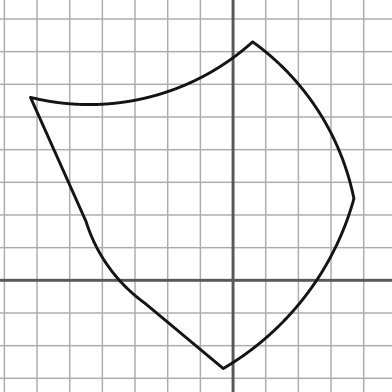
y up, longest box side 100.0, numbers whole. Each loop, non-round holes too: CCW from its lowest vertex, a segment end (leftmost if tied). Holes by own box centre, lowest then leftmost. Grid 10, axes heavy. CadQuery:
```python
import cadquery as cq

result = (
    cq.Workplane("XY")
    .moveTo(-3.0, -27.0)
    .threePointArc((22.0, -5.0), (37.0, 25.0))
    .threePointArc((26.0, 52.0), (6.0, 73.0))
    .threePointArc((-26.0, 56.0), (-62.0, 56.0))
    .lineTo(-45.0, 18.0)
    .threePointArc((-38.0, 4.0), (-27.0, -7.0))
    .close()
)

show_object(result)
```